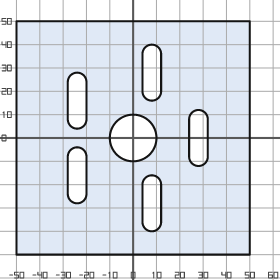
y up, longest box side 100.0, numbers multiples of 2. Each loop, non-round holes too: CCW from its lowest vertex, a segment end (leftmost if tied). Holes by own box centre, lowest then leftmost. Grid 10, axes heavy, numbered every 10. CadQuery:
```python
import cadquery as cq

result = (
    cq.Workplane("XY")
    .moveTo(-50.0, -50.0)
    .lineTo(50.0, -50.0)
    .lineTo(50.0, 50.0)
    .lineTo(-50.0, 50.0)
    .close()
    .moveTo(4.0, -36.0)
    .threePointArc((8.0, -40.0), (12.0, -36.0))
    .lineTo(12.0, -20.0)
    .threePointArc((8.0, -16.0), (4.0, -20.0))
    .close()
    .moveTo(-28.0, -24.0)
    .threePointArc((-24.0, -28.0), (-20.0, -24.0))
    .lineTo(-20.0, -8.0)
    .threePointArc((-24.0, -4.0), (-28.0, -8.0))
    .close()
    .moveTo(0.0, 0.0)
    .circle(10.0)
    .moveTo(24.0, -8.0)
    .threePointArc((28.0, -12.0), (32.0, -8.0))
    .lineTo(32.0, 8.0)
    .threePointArc((28.0, 12.0), (24.0, 8.0))
    .close()
    .moveTo(-28.0, 8.0)
    .threePointArc((-24.0, 4.0), (-20.0, 8.0))
    .lineTo(-20.0, 24.0)
    .threePointArc((-24.0, 28.0), (-28.0, 24.0))
    .close()
    .moveTo(4.0, 20.0)
    .threePointArc((8.0, 16.0), (12.0, 20.0))
    .lineTo(12.0, 36.0)
    .threePointArc((8.0, 40.0), (4.0, 36.0))
    .close()
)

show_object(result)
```